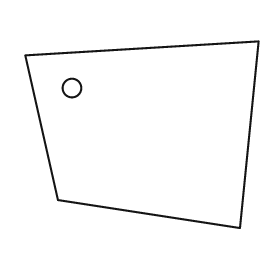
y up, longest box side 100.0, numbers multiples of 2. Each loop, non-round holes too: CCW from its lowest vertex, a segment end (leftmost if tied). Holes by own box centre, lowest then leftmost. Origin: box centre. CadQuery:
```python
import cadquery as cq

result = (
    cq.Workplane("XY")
    .moveTo(42.0, -40.0)
    .lineTo(50.0, 40.0)
    .lineTo(-50.0, 34.0)
    .lineTo(-36.0, -28.0)
    .close()
    .moveTo(-30.0, 20.0)
    .circle(4.0)
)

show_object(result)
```